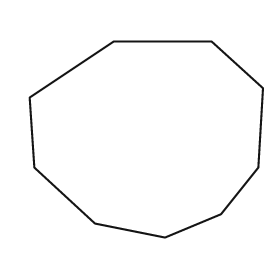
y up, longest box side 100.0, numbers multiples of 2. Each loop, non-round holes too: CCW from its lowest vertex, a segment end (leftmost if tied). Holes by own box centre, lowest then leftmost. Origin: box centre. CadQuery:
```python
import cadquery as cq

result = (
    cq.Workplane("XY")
    .moveTo(8.0, -42.0)
    .lineTo(32.0, -32.0)
    .lineTo(48.0, -12.0)
    .lineTo(50.0, 22.0)
    .lineTo(28.0, 42.0)
    .lineTo(-14.0, 42.0)
    .lineTo(-50.0, 18.0)
    .lineTo(-48.0, -12.0)
    .lineTo(-22.0, -36.0)
    .close()
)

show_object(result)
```